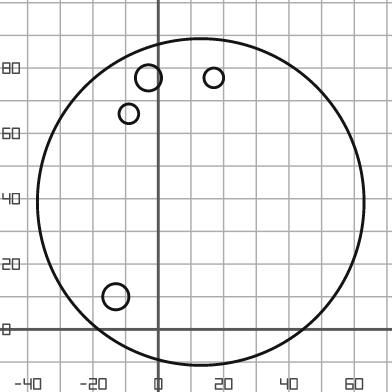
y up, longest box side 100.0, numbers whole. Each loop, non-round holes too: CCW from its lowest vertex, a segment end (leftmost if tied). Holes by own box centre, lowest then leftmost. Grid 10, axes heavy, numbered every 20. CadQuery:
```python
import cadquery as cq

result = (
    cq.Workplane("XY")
    .moveTo(13.0, 39.0)
    .circle(50.0)
    .moveTo(-13.0, 10.0)
    .circle(4.0)
    .moveTo(-9.0, 66.0)
    .circle(3.0)
    .moveTo(-3.0, 77.0)
    .circle(4.0)
    .moveTo(17.0, 77.0)
    .circle(3.0)
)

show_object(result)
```